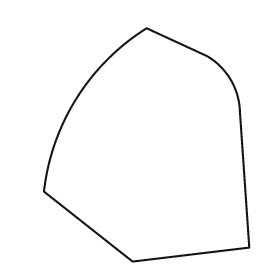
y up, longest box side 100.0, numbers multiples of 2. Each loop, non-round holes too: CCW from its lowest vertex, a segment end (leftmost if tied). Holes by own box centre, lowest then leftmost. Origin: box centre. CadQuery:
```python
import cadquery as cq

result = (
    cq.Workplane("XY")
    .moveTo(-6.0, -50.0)
    .lineTo(44.0, -44.0)
    .lineTo(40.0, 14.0)
    .threePointArc((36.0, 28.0), (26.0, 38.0))
    .lineTo(0.0, 50.0)
    .threePointArc((-30.0, 20.0), (-44.0, -20.0))
    .close()
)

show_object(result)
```